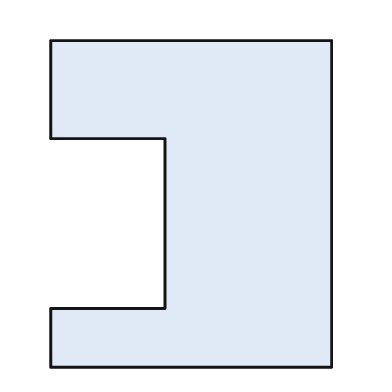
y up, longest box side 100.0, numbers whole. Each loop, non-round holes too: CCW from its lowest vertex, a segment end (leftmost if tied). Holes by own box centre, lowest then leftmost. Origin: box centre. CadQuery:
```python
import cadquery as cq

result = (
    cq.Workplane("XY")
    .moveTo(-43.0, -50.0)
    .lineTo(43.0, -50.0)
    .lineTo(43.0, 50.0)
    .lineTo(-43.0, 50.0)
    .lineTo(-43.0, 20.0)
    .lineTo(-8.0, 20.0)
    .lineTo(-8.0, -32.0)
    .lineTo(-43.0, -32.0)
    .close()
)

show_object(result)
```